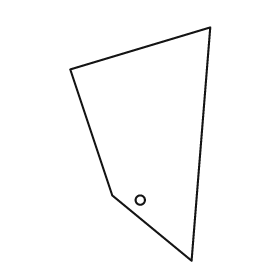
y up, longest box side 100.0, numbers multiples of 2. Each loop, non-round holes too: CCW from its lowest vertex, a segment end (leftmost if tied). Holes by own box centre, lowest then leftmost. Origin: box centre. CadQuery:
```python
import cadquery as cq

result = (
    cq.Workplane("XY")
    .moveTo(22.0, -50.0)
    .lineTo(30.0, 50.0)
    .lineTo(-30.0, 32.0)
    .lineTo(-12.0, -22.0)
    .close()
    .moveTo(0.0, -24.0)
    .circle(2.0)
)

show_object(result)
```